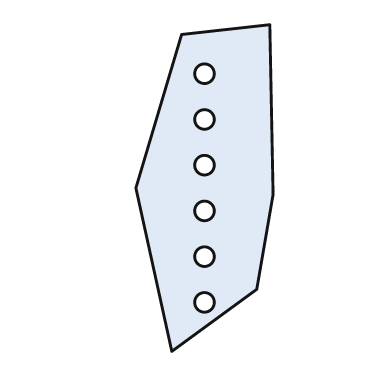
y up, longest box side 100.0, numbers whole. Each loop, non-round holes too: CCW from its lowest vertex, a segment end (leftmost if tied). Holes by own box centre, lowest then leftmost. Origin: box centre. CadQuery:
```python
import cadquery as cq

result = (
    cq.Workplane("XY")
    .moveTo(-10.0, -50.0)
    .lineTo(16.0, -31.0)
    .lineTo(21.0, -2.0)
    .lineTo(20.0, 50.0)
    .lineTo(-7.0, 47.0)
    .lineTo(-21.0, 0.0)
    .close()
    .moveTo(0.0, -35.0)
    .circle(3.0)
    .moveTo(0.0, -21.0)
    .circle(3.0)
    .moveTo(0.0, -7.0)
    .circle(3.0)
    .moveTo(0.0, 7.0)
    .circle(3.0)
    .moveTo(0.0, 21.0)
    .circle(3.0)
    .moveTo(0.0, 35.0)
    .circle(3.0)
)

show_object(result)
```